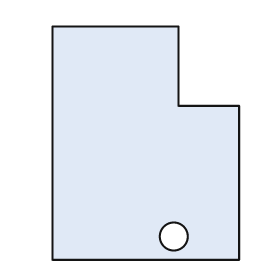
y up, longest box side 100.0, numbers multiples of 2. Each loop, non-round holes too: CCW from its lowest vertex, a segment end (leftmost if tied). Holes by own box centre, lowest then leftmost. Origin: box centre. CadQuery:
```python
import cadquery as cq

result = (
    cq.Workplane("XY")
    .moveTo(-40.0, -50.0)
    .lineTo(40.0, -50.0)
    .lineTo(40.0, 16.0)
    .lineTo(14.0, 16.0)
    .lineTo(14.0, 50.0)
    .lineTo(-40.0, 50.0)
    .close()
    .moveTo(12.0, -40.0)
    .circle(6.0)
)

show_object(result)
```